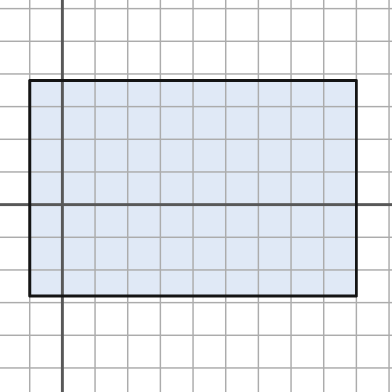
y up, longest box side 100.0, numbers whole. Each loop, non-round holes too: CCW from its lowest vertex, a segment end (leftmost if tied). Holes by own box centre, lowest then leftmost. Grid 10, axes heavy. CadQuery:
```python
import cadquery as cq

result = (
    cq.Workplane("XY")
    .moveTo(-10.0, -28.0)
    .lineTo(90.0, -28.0)
    .lineTo(90.0, 38.0)
    .lineTo(-10.0, 38.0)
    .close()
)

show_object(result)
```